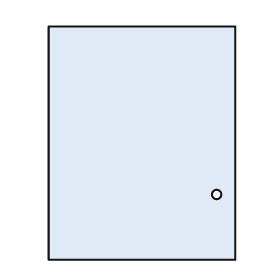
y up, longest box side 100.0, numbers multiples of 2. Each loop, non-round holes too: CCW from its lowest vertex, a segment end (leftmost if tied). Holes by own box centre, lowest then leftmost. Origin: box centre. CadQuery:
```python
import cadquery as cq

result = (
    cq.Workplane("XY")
    .moveTo(-40.0, -50.0)
    .lineTo(40.0, -50.0)
    .lineTo(40.0, 50.0)
    .lineTo(-40.0, 50.0)
    .close()
    .moveTo(32.0, -22.0)
    .circle(2.0)
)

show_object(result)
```